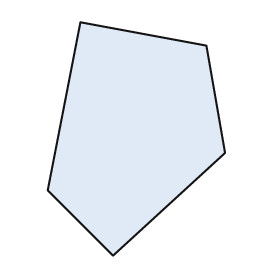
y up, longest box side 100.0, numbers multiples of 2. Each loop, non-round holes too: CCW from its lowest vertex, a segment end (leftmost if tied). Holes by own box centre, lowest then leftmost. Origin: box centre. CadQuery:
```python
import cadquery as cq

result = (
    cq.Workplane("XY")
    .moveTo(-10.0, -50.0)
    .lineTo(38.0, -6.0)
    .lineTo(30.0, 40.0)
    .lineTo(-24.0, 50.0)
    .lineTo(-38.0, -22.0)
    .close()
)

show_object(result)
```